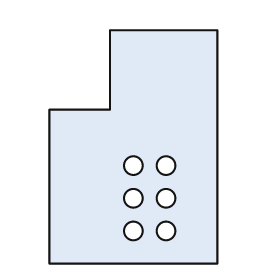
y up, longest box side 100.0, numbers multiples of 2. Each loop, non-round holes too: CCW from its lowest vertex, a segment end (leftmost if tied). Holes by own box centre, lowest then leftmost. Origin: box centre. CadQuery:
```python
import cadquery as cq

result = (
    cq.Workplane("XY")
    .moveTo(-36.0, -50.0)
    .lineTo(36.0, -50.0)
    .lineTo(36.0, 50.0)
    .lineTo(-10.0, 50.0)
    .lineTo(-10.0, 16.0)
    .lineTo(-36.0, 16.0)
    .close()
    .moveTo(0.0, -36.0)
    .circle(4.0)
    .moveTo(14.0, -36.0)
    .circle(4.0)
    .moveTo(0.0, -22.0)
    .circle(4.0)
    .moveTo(14.0, -22.0)
    .circle(4.0)
    .moveTo(0.0, -8.0)
    .circle(4.0)
    .moveTo(14.0, -8.0)
    .circle(4.0)
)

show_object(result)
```